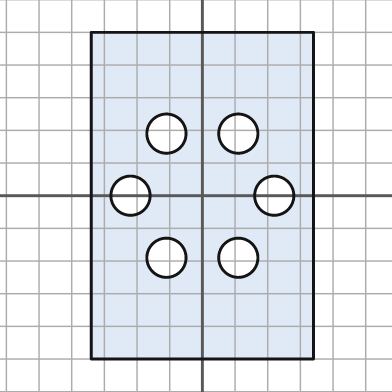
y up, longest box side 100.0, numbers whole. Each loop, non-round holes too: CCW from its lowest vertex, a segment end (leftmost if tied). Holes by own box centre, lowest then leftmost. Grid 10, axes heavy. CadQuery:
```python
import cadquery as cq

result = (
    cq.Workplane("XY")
    .moveTo(-34.0, -50.0)
    .lineTo(34.0, -50.0)
    .lineTo(34.0, 50.0)
    .lineTo(-34.0, 50.0)
    .close()
    .moveTo(-11.0, -19.0)
    .circle(6.0)
    .moveTo(11.0, -19.0)
    .circle(6.0)
    .moveTo(-22.0, 0.0)
    .circle(6.0)
    .moveTo(22.0, 0.0)
    .circle(6.0)
    .moveTo(-11.0, 19.0)
    .circle(6.0)
    .moveTo(11.0, 19.0)
    .circle(6.0)
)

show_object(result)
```